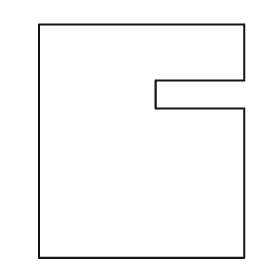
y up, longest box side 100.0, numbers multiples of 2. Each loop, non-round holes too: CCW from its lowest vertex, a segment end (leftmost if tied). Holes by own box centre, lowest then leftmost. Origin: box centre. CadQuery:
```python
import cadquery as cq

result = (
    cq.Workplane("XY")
    .moveTo(-44.0, -50.0)
    .lineTo(44.0, -50.0)
    .lineTo(44.0, 14.0)
    .lineTo(6.0, 14.0)
    .lineTo(6.0, 26.0)
    .lineTo(44.0, 26.0)
    .lineTo(44.0, 50.0)
    .lineTo(-44.0, 50.0)
    .close()
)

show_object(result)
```